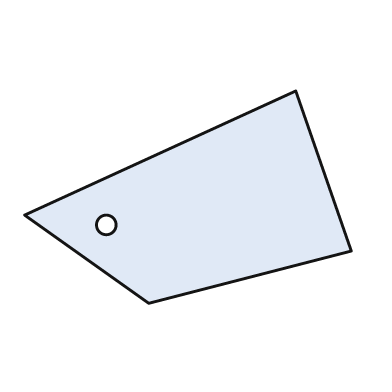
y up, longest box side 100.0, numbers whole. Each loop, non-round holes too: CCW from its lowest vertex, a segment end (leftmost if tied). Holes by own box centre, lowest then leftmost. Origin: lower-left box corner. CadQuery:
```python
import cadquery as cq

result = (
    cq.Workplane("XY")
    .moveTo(38.0, 0.0)
    .lineTo(100.0, 16.0)
    .lineTo(83.0, 65.0)
    .lineTo(0.0, 27.0)
    .close()
    .moveTo(25.0, 24.0)
    .circle(3.0)
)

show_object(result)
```